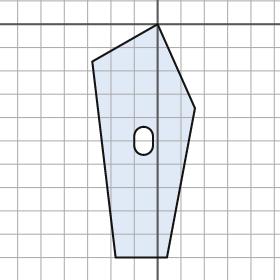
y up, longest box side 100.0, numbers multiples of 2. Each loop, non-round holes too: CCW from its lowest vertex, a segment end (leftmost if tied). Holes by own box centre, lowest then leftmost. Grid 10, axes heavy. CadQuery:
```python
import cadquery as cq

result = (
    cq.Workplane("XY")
    .moveTo(-18.0, -100.0)
    .lineTo(4.0, -100.0)
    .lineTo(16.0, -36.0)
    .lineTo(0.0, 0.0)
    .lineTo(-28.0, -16.0)
    .close()
    .moveTo(-10.0, -52.0)
    .threePointArc((-6.0, -56.0), (-2.0, -52.0))
    .lineTo(-2.0, -48.0)
    .threePointArc((-6.0, -44.0), (-10.0, -48.0))
    .close()
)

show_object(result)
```